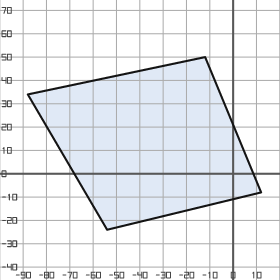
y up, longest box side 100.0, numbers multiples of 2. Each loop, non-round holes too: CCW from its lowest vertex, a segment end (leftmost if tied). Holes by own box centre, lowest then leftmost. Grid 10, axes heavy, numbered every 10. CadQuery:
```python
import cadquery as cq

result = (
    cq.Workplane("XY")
    .moveTo(-54.0, -24.0)
    .lineTo(12.0, -8.0)
    .lineTo(-12.0, 50.0)
    .lineTo(-88.0, 34.0)
    .close()
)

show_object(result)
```